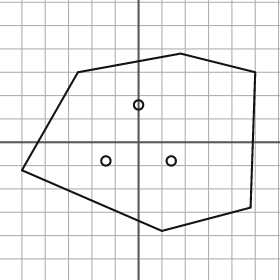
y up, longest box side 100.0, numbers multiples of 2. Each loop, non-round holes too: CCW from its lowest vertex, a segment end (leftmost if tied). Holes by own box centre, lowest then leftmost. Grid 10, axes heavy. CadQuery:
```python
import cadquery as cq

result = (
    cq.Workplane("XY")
    .moveTo(10.0, -38.0)
    .lineTo(48.0, -28.0)
    .lineTo(50.0, 30.0)
    .lineTo(18.0, 38.0)
    .lineTo(-26.0, 30.0)
    .lineTo(-50.0, -12.0)
    .close()
    .moveTo(-14.0, -8.0)
    .circle(2.0)
    .moveTo(14.0, -8.0)
    .circle(2.0)
    .moveTo(0.0, 16.0)
    .circle(2.0)
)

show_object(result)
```